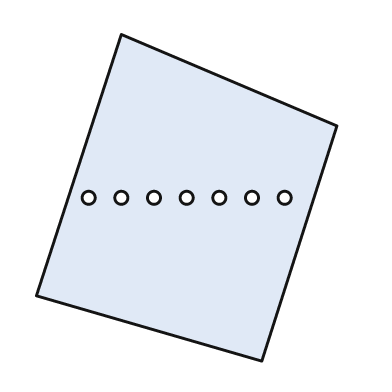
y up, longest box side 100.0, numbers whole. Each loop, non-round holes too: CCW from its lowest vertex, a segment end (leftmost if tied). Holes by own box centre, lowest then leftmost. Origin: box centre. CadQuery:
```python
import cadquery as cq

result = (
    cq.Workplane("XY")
    .moveTo(23.0, -50.0)
    .lineTo(46.0, 22.0)
    .lineTo(-20.0, 50.0)
    .lineTo(-46.0, -30.0)
    .close()
    .moveTo(-30.0, 0.0)
    .circle(2.0)
    .moveTo(-20.0, 0.0)
    .circle(2.0)
    .moveTo(-10.0, 0.0)
    .circle(2.0)
    .moveTo(0.0, 0.0)
    .circle(2.0)
    .moveTo(10.0, 0.0)
    .circle(2.0)
    .moveTo(20.0, 0.0)
    .circle(2.0)
    .moveTo(30.0, 0.0)
    .circle(2.0)
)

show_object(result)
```